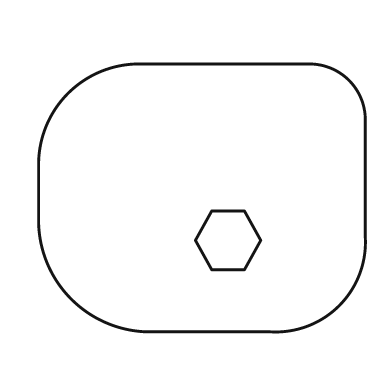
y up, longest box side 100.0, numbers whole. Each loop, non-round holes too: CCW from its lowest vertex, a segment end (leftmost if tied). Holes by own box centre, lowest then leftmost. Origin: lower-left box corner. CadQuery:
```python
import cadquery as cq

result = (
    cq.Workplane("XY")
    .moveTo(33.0, 0.0)
    .lineTo(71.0, 0.0)
    .threePointArc((92.0, 8.0), (100.0, 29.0))
    .lineTo(100.0, 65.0)
    .threePointArc((95.0, 77.0), (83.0, 82.0))
    .lineTo(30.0, 82.0)
    .threePointArc((9.0, 73.0), (0.0, 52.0))
    .lineTo(0.0, 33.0)
    .threePointArc((10.0, 10.0), (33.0, 0.0))
    .close()
    .moveTo(53.0, 19.0)
    .lineTo(63.0, 19.0)
    .lineTo(68.0, 28.0)
    .lineTo(63.0, 37.0)
    .lineTo(53.0, 37.0)
    .lineTo(48.0, 28.0)
    .close()
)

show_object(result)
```